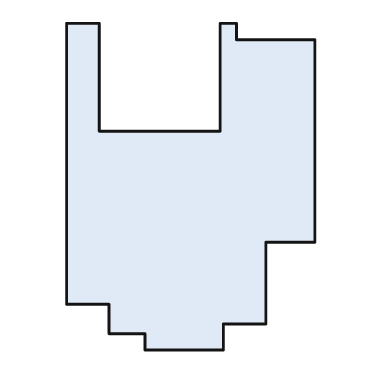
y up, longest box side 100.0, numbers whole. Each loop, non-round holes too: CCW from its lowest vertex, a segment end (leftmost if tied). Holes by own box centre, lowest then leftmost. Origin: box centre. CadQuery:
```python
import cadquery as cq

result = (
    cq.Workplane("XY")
    .moveTo(-14.0, -50.0)
    .lineTo(10.0, -50.0)
    .lineTo(10.0, -42.0)
    .lineTo(23.0, -42.0)
    .lineTo(23.0, -17.0)
    .lineTo(38.0, -17.0)
    .lineTo(38.0, 45.0)
    .lineTo(14.0, 45.0)
    .lineTo(14.0, 50.0)
    .lineTo(9.0, 50.0)
    .lineTo(9.0, 17.0)
    .lineTo(-28.0, 17.0)
    .lineTo(-28.0, 50.0)
    .lineTo(-38.0, 50.0)
    .lineTo(-38.0, -36.0)
    .lineTo(-25.0, -36.0)
    .lineTo(-25.0, -45.0)
    .lineTo(-14.0, -45.0)
    .close()
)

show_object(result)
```